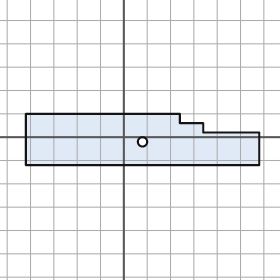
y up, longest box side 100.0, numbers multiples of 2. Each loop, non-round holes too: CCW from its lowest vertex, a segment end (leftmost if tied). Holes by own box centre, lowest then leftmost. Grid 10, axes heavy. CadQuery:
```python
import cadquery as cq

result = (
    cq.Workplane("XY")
    .moveTo(-42.0, -12.0)
    .lineTo(58.0, -12.0)
    .lineTo(58.0, 2.0)
    .lineTo(34.0, 2.0)
    .lineTo(34.0, 6.0)
    .lineTo(24.0, 6.0)
    .lineTo(24.0, 10.0)
    .lineTo(-42.0, 10.0)
    .close()
    .moveTo(8.0, -2.0)
    .circle(2.0)
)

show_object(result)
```